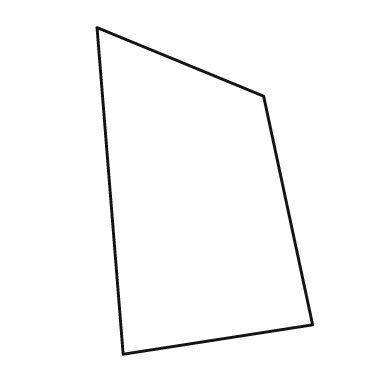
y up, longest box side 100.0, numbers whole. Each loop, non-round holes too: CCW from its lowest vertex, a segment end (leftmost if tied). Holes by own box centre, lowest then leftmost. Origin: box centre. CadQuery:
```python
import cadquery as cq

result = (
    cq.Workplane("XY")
    .moveTo(-25.0, -50.0)
    .lineTo(33.0, -41.0)
    .lineTo(18.0, 29.0)
    .lineTo(-33.0, 50.0)
    .close()
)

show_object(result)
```